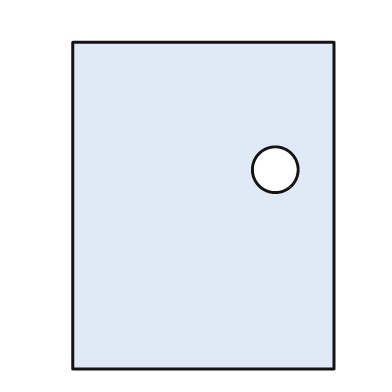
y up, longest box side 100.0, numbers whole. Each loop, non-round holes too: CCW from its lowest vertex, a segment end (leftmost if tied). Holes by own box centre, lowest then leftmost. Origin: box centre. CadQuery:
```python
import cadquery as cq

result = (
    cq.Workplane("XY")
    .moveTo(-40.0, -50.0)
    .lineTo(40.0, -50.0)
    .lineTo(40.0, 50.0)
    .lineTo(-40.0, 50.0)
    .close()
    .moveTo(22.0, 11.0)
    .circle(7.0)
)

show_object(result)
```